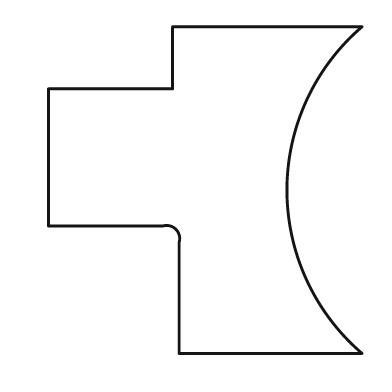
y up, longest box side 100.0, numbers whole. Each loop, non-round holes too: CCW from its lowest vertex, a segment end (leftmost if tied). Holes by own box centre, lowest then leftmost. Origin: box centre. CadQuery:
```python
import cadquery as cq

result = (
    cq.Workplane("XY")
    .moveTo(-8.0, -50.0)
    .lineTo(48.0, -50.0)
    .threePointArc((25.0, 0.0), (48.0, 50.0))
    .lineTo(-10.0, 50.0)
    .lineTo(-10.0, 31.0)
    .lineTo(-48.0, 31.0)
    .lineTo(-48.0, -11.0)
    .lineTo(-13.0, -11.0)
    .threePointArc((-9.0, -12.0), (-8.0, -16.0))
    .close()
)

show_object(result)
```